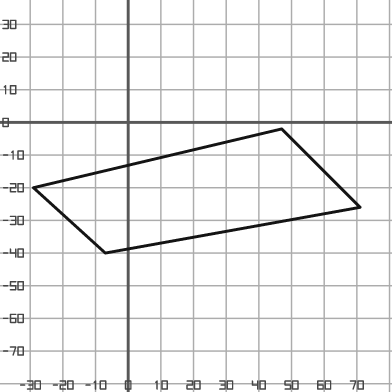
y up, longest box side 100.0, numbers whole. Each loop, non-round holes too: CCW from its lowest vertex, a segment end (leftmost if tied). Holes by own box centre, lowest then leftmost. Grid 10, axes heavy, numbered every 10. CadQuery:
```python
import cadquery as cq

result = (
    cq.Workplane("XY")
    .moveTo(-7.0, -40.0)
    .lineTo(71.0, -26.0)
    .lineTo(47.0, -2.0)
    .lineTo(-29.0, -20.0)
    .close()
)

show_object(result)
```